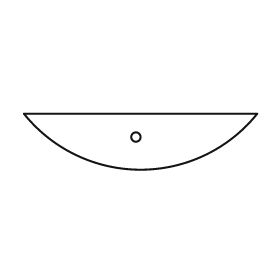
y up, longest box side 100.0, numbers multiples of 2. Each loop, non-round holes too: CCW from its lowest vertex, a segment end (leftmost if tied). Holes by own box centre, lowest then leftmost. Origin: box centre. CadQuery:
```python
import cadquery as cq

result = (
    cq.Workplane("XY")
    .moveTo(-50.0, 12.0)
    .threePointArc((0.0, -12.0), (50.0, 12.0))
    .close()
    .moveTo(-2.0, 2.0)
    .circle(2.0)
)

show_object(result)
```